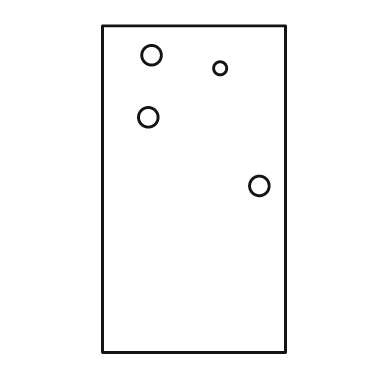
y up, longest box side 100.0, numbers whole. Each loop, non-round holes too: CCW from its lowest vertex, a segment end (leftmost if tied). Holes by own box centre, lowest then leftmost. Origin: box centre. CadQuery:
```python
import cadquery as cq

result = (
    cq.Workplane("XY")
    .moveTo(-28.0, -50.0)
    .lineTo(28.0, -50.0)
    .lineTo(28.0, 50.0)
    .lineTo(-28.0, 50.0)
    .close()
    .moveTo(20.0, 1.0)
    .circle(3.0)
    .moveTo(-14.0, 22.0)
    .circle(3.0)
    .moveTo(8.0, 37.0)
    .circle(2.0)
    .moveTo(-13.0, 41.0)
    .circle(3.0)
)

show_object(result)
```